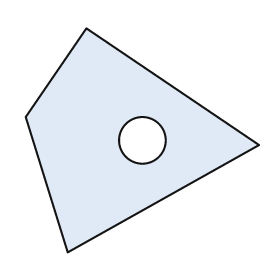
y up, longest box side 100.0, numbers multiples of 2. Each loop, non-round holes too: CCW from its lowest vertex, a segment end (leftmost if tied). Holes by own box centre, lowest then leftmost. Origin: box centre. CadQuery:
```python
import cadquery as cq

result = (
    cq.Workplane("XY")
    .moveTo(-32.0, -48.0)
    .lineTo(50.0, -2.0)
    .lineTo(-24.0, 48.0)
    .lineTo(-50.0, 10.0)
    .close()
    .moveTo(0.0, 0.0)
    .circle(10.0)
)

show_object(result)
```